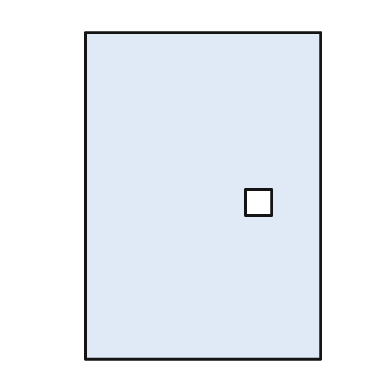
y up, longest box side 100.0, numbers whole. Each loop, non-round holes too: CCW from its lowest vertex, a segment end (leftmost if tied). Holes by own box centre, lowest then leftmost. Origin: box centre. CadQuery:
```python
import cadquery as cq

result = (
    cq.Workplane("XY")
    .moveTo(-36.0, -50.0)
    .lineTo(36.0, -50.0)
    .lineTo(36.0, 50.0)
    .lineTo(-36.0, 50.0)
    .close()
    .moveTo(13.0, -6.0)
    .lineTo(21.0, -6.0)
    .lineTo(21.0, 2.0)
    .lineTo(13.0, 2.0)
    .close()
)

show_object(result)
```